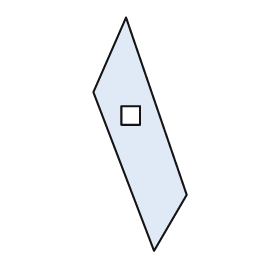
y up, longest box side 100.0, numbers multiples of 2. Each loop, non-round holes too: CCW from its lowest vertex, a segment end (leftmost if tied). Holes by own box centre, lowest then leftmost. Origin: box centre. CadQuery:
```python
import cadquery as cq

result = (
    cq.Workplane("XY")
    .moveTo(6.0, -50.0)
    .lineTo(20.0, -26.0)
    .lineTo(-6.0, 50.0)
    .lineTo(-20.0, 18.0)
    .close()
    .moveTo(-8.0, 4.0)
    .lineTo(0.0, 4.0)
    .lineTo(0.0, 12.0)
    .lineTo(-8.0, 12.0)
    .close()
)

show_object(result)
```